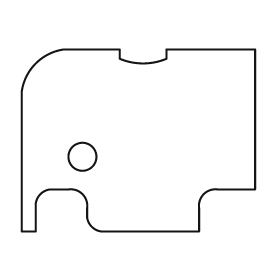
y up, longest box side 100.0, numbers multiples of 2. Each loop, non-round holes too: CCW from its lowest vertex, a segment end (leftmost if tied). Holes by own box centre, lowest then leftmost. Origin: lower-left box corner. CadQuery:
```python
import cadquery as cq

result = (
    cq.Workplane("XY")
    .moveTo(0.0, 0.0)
    .lineTo(6.0, 0.0)
    .lineTo(6.0, 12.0)
    .threePointArc((8.0, 16.0), (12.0, 18.0))
    .lineTo(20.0, 18.0)
    .threePointArc((26.0, 16.0), (28.0, 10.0))
    .lineTo(28.0, 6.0)
    .threePointArc((30.0, 2.0), (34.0, 0.0))
    .lineTo(76.0, 0.0)
    .lineTo(76.0, 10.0)
    .threePointArc((78.0, 16.0), (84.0, 18.0))
    .lineTo(100.0, 18.0)
    .lineTo(100.0, 78.0)
    .lineTo(62.0, 78.0)
    .lineTo(62.0, 74.0)
    .threePointArc((52.0, 72.0), (42.0, 74.0))
    .lineTo(42.0, 78.0)
    .lineTo(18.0, 78.0)
    .threePointArc((6.0, 72.0), (0.0, 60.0))
    .close()
    .moveTo(26.0, 32.0)
    .circle(6.0)
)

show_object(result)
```